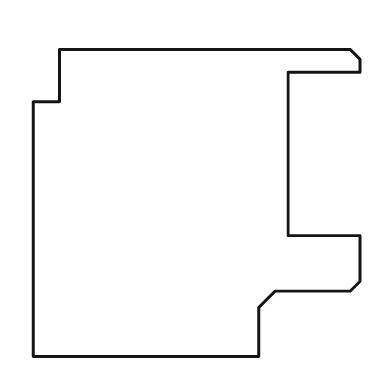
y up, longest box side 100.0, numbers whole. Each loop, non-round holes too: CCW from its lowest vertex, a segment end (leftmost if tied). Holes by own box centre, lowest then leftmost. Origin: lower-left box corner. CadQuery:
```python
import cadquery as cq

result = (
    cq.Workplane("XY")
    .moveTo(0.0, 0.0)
    .lineTo(69.0, 0.0)
    .lineTo(69.0, 15.0)
    .lineTo(74.0, 20.0)
    .lineTo(97.0, 20.0)
    .lineTo(100.0, 23.0)
    .lineTo(100.0, 37.0)
    .lineTo(78.0, 37.0)
    .lineTo(78.0, 87.0)
    .lineTo(100.0, 87.0)
    .lineTo(100.0, 91.0)
    .lineTo(97.0, 94.0)
    .lineTo(8.0, 94.0)
    .lineTo(8.0, 78.0)
    .lineTo(0.0, 78.0)
    .close()
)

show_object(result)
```